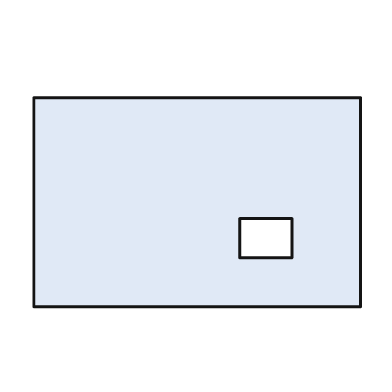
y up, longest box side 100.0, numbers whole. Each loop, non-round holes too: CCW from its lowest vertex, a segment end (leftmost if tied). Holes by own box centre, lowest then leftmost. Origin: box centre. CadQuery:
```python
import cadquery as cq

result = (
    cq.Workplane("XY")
    .moveTo(-50.0, -32.0)
    .lineTo(50.0, -32.0)
    .lineTo(50.0, 32.0)
    .lineTo(-50.0, 32.0)
    .close()
    .moveTo(13.0, -17.0)
    .lineTo(29.0, -17.0)
    .lineTo(29.0, -5.0)
    .lineTo(13.0, -5.0)
    .close()
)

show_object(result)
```